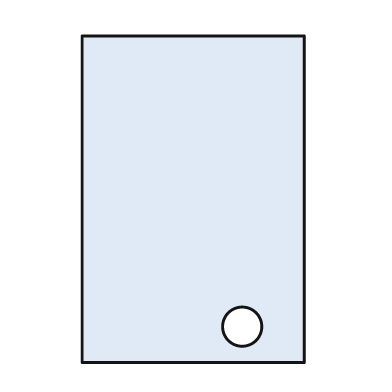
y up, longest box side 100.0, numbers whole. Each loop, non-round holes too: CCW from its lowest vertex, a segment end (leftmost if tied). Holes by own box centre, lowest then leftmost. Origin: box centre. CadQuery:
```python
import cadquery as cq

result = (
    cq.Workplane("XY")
    .moveTo(-34.0, -50.0)
    .lineTo(34.0, -50.0)
    .lineTo(34.0, 50.0)
    .lineTo(-34.0, 50.0)
    .close()
    .moveTo(15.0, -39.0)
    .circle(6.0)
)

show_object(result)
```